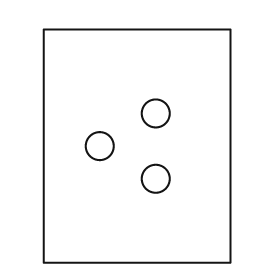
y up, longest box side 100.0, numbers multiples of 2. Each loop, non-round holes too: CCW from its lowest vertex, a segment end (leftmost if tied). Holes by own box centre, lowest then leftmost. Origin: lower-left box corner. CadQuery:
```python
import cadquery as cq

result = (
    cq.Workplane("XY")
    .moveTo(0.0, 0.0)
    .lineTo(80.0, 0.0)
    .lineTo(80.0, 100.0)
    .lineTo(0.0, 100.0)
    .close()
    .moveTo(48.0, 36.0)
    .circle(6.0)
    .moveTo(24.0, 50.0)
    .circle(6.0)
    .moveTo(48.0, 64.0)
    .circle(6.0)
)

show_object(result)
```